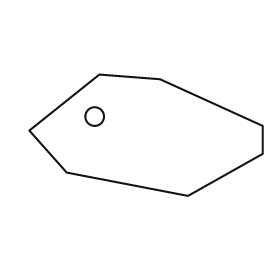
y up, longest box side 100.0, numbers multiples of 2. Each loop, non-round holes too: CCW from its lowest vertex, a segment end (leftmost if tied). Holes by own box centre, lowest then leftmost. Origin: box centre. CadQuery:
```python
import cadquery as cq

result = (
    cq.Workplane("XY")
    .moveTo(18.0, -26.0)
    .lineTo(50.0, -8.0)
    .lineTo(50.0, 4.0)
    .lineTo(6.0, 24.0)
    .lineTo(-20.0, 26.0)
    .lineTo(-50.0, 2.0)
    .lineTo(-34.0, -16.0)
    .close()
    .moveTo(-22.0, 8.0)
    .circle(4.0)
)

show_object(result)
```